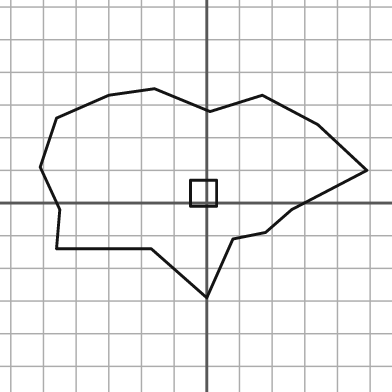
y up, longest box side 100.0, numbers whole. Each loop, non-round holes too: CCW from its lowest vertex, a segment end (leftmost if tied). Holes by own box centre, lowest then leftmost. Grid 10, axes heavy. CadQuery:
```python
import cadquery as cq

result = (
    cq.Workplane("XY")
    .moveTo(0.0, -29.0)
    .lineTo(8.0, -11.0)
    .lineTo(18.0, -9.0)
    .lineTo(26.0, -2.0)
    .lineTo(49.0, 10.0)
    .lineTo(34.0, 24.0)
    .lineTo(17.0, 33.0)
    .lineTo(1.0, 28.0)
    .lineTo(-16.0, 35.0)
    .lineTo(-30.0, 33.0)
    .lineTo(-46.0, 26.0)
    .lineTo(-51.0, 11.0)
    .lineTo(-45.0, -2.0)
    .lineTo(-46.0, -14.0)
    .lineTo(-17.0, -14.0)
    .close()
    .moveTo(-5.0, -1.0)
    .lineTo(3.0, -1.0)
    .lineTo(3.0, 7.0)
    .lineTo(-5.0, 7.0)
    .close()
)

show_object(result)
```